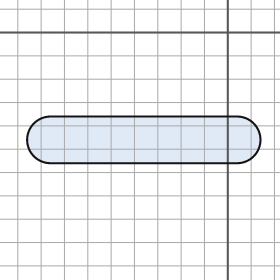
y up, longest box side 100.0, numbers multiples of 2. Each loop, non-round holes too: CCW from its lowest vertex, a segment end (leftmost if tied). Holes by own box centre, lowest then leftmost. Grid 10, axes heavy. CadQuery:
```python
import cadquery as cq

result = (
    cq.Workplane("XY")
    .moveTo(-76.0, -56.0)
    .lineTo(4.0, -56.0)
    .threePointArc((14.0, -46.0), (4.0, -36.0))
    .lineTo(-76.0, -36.0)
    .threePointArc((-86.0, -46.0), (-76.0, -56.0))
    .close()
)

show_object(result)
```